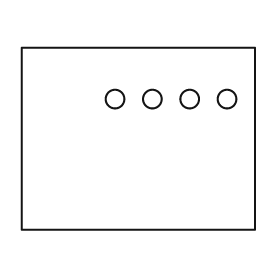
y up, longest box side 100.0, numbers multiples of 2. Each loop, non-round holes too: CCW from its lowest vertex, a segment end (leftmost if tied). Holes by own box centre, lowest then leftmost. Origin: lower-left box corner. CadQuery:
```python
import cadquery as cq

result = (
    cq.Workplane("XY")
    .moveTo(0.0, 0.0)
    .lineTo(100.0, 0.0)
    .lineTo(100.0, 78.0)
    .lineTo(0.0, 78.0)
    .close()
    .moveTo(40.0, 56.0)
    .circle(4.0)
    .moveTo(56.0, 56.0)
    .circle(4.0)
    .moveTo(72.0, 56.0)
    .circle(4.0)
    .moveTo(88.0, 56.0)
    .circle(4.0)
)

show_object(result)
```